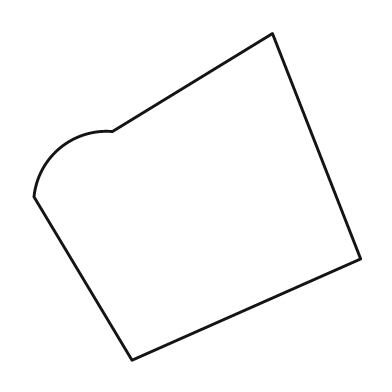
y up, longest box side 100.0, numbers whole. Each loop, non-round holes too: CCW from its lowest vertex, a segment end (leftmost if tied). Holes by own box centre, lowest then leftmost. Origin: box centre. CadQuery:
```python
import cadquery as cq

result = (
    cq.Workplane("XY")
    .moveTo(-20.0, -50.0)
    .lineTo(50.0, -19.0)
    .lineTo(23.0, 50.0)
    .lineTo(-26.0, 20.0)
    .threePointArc((-42.0, 15.0), (-50.0, 0.0))
    .close()
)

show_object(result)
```